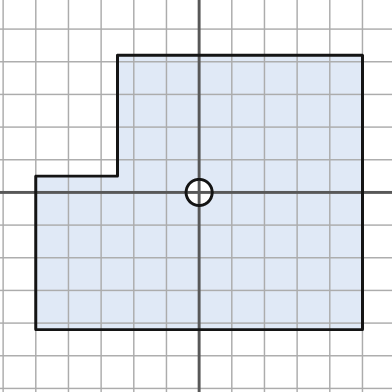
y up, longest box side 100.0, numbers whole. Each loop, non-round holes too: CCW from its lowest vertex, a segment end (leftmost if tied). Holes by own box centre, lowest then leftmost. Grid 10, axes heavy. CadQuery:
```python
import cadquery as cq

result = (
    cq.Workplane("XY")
    .moveTo(-50.0, -42.0)
    .lineTo(50.0, -42.0)
    .lineTo(50.0, 42.0)
    .lineTo(-25.0, 42.0)
    .lineTo(-25.0, 5.0)
    .lineTo(-50.0, 5.0)
    .close()
    .moveTo(0.0, 0.0)
    .circle(4.0)
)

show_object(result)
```